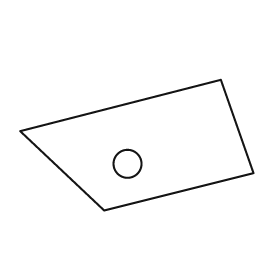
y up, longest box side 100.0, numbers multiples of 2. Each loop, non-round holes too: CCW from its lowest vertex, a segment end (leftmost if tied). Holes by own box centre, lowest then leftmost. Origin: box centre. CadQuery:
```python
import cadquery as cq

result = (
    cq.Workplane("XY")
    .moveTo(-14.0, -28.0)
    .lineTo(50.0, -12.0)
    .lineTo(36.0, 28.0)
    .lineTo(-50.0, 6.0)
    .close()
    .moveTo(-4.0, -8.0)
    .circle(6.0)
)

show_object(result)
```